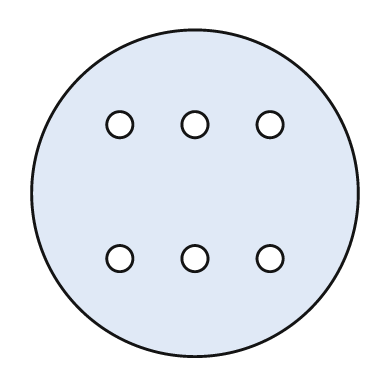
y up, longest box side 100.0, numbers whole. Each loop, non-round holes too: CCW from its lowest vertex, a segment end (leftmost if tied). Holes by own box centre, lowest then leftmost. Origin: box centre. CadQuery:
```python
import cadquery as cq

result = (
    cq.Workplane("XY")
    .moveTo(0.0, 0.0)
    .circle(50.0)
    .moveTo(-23.0, -20.0)
    .circle(4.0)
    .moveTo(0.0, -20.0)
    .circle(4.0)
    .moveTo(23.0, -20.0)
    .circle(4.0)
    .moveTo(-23.0, 21.0)
    .circle(4.0)
    .moveTo(0.0, 21.0)
    .circle(4.0)
    .moveTo(23.0, 21.0)
    .circle(4.0)
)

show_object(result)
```